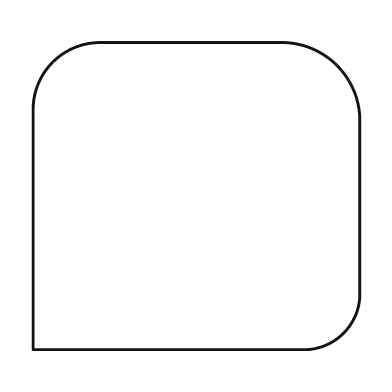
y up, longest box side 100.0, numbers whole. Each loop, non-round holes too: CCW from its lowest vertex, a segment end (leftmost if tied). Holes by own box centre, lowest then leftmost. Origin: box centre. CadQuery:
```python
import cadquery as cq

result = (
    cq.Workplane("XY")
    .moveTo(-50.0, -47.0)
    .lineTo(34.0, -47.0)
    .threePointArc((45.0, -42.0), (50.0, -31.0))
    .lineTo(50.0, 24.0)
    .threePointArc((43.0, 40.0), (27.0, 47.0))
    .lineTo(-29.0, 47.0)
    .threePointArc((-44.0, 41.0), (-50.0, 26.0))
    .close()
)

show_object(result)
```